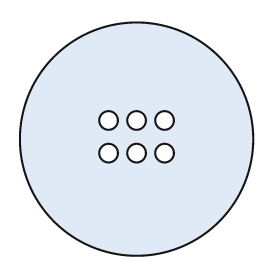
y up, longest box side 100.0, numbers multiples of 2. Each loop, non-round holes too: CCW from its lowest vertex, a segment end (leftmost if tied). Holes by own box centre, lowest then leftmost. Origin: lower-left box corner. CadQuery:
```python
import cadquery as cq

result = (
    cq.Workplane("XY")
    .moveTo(50.0, 50.0)
    .circle(50.0)
    .moveTo(38.0, 44.0)
    .circle(4.0)
    .moveTo(50.0, 44.0)
    .circle(4.0)
    .moveTo(62.0, 44.0)
    .circle(4.0)
    .moveTo(38.0, 58.0)
    .circle(4.0)
    .moveTo(50.0, 58.0)
    .circle(4.0)
    .moveTo(62.0, 58.0)
    .circle(4.0)
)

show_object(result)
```